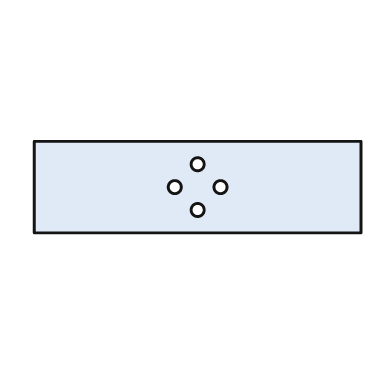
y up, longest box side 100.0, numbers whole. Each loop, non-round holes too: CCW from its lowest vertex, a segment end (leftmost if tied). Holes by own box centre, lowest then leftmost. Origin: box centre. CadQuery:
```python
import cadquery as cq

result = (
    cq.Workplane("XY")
    .moveTo(-50.0, -14.0)
    .lineTo(50.0, -14.0)
    .lineTo(50.0, 14.0)
    .lineTo(-50.0, 14.0)
    .close()
    .moveTo(0.0, -7.0)
    .circle(2.0)
    .moveTo(-7.0, 0.0)
    .circle(2.0)
    .moveTo(7.0, 0.0)
    .circle(2.0)
    .moveTo(0.0, 7.0)
    .circle(2.0)
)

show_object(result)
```